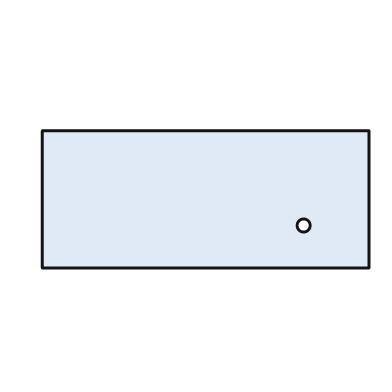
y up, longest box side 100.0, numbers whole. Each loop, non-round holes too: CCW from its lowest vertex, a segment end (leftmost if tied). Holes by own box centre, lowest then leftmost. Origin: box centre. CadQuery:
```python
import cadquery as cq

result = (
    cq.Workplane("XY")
    .moveTo(-50.0, -21.0)
    .lineTo(50.0, -21.0)
    .lineTo(50.0, 21.0)
    .lineTo(-50.0, 21.0)
    .close()
    .moveTo(30.0, -8.0)
    .circle(2.0)
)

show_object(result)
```